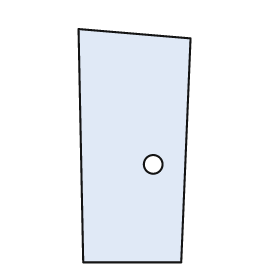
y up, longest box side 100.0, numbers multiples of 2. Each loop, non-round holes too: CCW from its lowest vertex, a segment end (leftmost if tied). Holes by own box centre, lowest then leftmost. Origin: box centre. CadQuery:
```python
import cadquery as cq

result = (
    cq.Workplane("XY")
    .moveTo(-22.0, -50.0)
    .lineTo(20.0, -50.0)
    .lineTo(24.0, 46.0)
    .lineTo(-24.0, 50.0)
    .close()
    .moveTo(8.0, -8.0)
    .circle(4.0)
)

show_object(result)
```